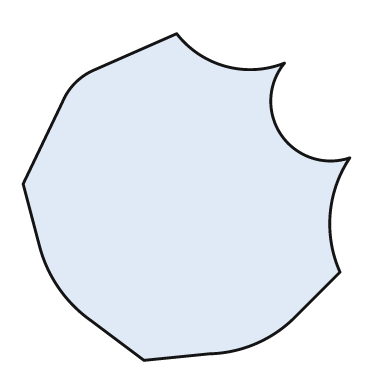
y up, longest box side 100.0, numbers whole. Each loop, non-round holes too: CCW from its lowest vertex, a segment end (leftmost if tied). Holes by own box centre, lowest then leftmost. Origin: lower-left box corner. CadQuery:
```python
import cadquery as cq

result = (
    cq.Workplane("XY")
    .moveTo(37.0, 0.0)
    .lineTo(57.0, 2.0)
    .threePointArc((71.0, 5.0), (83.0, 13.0))
    .lineTo(97.0, 27.0)
    .threePointArc((94.0, 45.0), (100.0, 62.0))
    .threePointArc((79.0, 69.0), (80.0, 91.0))
    .threePointArc((62.0, 90.0), (47.0, 100.0))
    .lineTo(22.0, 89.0)
    .threePointArc((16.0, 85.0), (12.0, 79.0))
    .lineTo(0.0, 54.0)
    .lineTo(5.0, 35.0)
    .threePointArc((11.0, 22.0), (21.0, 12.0))
    .close()
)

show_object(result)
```